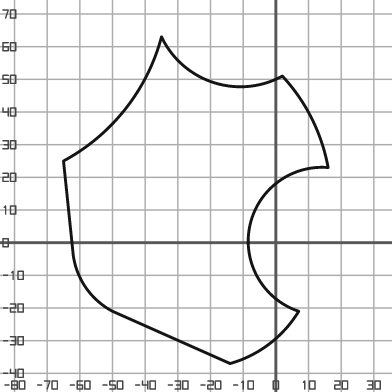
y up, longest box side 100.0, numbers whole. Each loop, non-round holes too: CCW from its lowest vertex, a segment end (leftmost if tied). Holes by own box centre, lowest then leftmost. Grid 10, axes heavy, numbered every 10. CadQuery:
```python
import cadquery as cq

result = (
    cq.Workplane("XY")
    .moveTo(-14.0, -37.0)
    .threePointArc((-2.0, -31.0), (7.0, -21.0))
    .threePointArc((-8.0, 5.0), (16.0, 23.0))
    .threePointArc((11.0, 38.0), (2.0, 51.0))
    .threePointArc((-19.0, 49.0), (-35.0, 63.0))
    .threePointArc((-46.0, 41.0), (-65.0, 25.0))
    .lineTo(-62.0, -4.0)
    .threePointArc((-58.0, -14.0), (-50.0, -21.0))
    .close()
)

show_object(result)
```